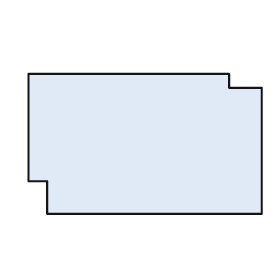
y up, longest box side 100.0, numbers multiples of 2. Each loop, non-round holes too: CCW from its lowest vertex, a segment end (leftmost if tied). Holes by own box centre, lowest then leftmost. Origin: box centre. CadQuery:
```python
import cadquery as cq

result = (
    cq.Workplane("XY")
    .moveTo(-42.0, -30.0)
    .lineTo(50.0, -30.0)
    .lineTo(50.0, 24.0)
    .lineTo(36.0, 24.0)
    .lineTo(36.0, 30.0)
    .lineTo(-50.0, 30.0)
    .lineTo(-50.0, -16.0)
    .lineTo(-42.0, -16.0)
    .close()
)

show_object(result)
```